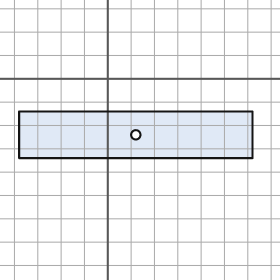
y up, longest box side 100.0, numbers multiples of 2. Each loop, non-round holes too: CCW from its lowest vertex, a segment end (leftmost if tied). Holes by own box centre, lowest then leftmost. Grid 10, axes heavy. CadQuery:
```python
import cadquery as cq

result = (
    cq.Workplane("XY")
    .moveTo(-38.0, -34.0)
    .lineTo(62.0, -34.0)
    .lineTo(62.0, -14.0)
    .lineTo(-38.0, -14.0)
    .close()
    .moveTo(12.0, -24.0)
    .circle(2.0)
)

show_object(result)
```